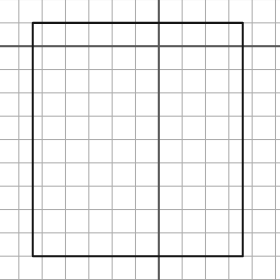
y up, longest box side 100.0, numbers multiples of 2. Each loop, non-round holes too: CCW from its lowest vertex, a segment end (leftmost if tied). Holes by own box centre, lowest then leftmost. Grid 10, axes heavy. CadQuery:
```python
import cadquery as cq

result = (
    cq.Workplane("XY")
    .moveTo(-54.0, -90.0)
    .lineTo(36.0, -90.0)
    .lineTo(36.0, 10.0)
    .lineTo(-54.0, 10.0)
    .close()
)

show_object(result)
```